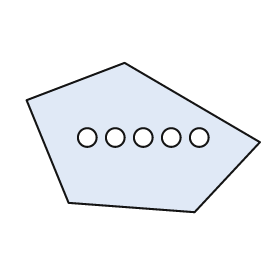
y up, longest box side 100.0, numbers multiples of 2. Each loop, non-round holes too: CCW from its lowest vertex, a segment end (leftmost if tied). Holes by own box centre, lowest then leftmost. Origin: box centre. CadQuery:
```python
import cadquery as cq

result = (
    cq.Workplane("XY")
    .moveTo(22.0, -32.0)
    .lineTo(50.0, -2.0)
    .lineTo(-8.0, 32.0)
    .lineTo(-50.0, 16.0)
    .lineTo(-32.0, -28.0)
    .close()
    .moveTo(-24.0, 0.0)
    .circle(4.0)
    .moveTo(-12.0, 0.0)
    .circle(4.0)
    .moveTo(0.0, 0.0)
    .circle(4.0)
    .moveTo(12.0, 0.0)
    .circle(4.0)
    .moveTo(24.0, 0.0)
    .circle(4.0)
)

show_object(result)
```